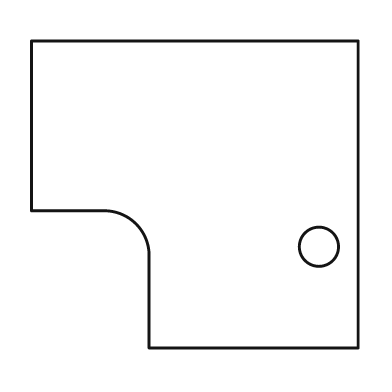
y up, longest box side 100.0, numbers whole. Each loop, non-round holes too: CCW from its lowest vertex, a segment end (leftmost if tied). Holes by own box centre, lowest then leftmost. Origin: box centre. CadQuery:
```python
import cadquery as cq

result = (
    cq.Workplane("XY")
    .moveTo(-14.0, -47.0)
    .lineTo(50.0, -47.0)
    .lineTo(50.0, 47.0)
    .lineTo(-50.0, 47.0)
    .lineTo(-50.0, -5.0)
    .lineTo(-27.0, -5.0)
    .threePointArc((-18.0, -9.0), (-14.0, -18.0))
    .close()
    .moveTo(38.0, -16.0)
    .circle(6.0)
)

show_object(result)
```